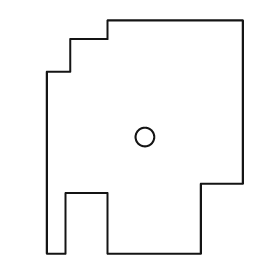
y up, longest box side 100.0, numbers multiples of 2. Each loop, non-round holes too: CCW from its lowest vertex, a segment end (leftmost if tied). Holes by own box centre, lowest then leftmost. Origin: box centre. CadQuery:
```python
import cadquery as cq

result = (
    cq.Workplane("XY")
    .moveTo(-42.0, -50.0)
    .lineTo(-34.0, -50.0)
    .lineTo(-34.0, -24.0)
    .lineTo(-16.0, -24.0)
    .lineTo(-16.0, -50.0)
    .lineTo(24.0, -50.0)
    .lineTo(24.0, -20.0)
    .lineTo(42.0, -20.0)
    .lineTo(42.0, 50.0)
    .lineTo(-16.0, 50.0)
    .lineTo(-16.0, 42.0)
    .lineTo(-32.0, 42.0)
    .lineTo(-32.0, 28.0)
    .lineTo(-42.0, 28.0)
    .close()
    .moveTo(0.0, 0.0)
    .circle(4.0)
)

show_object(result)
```